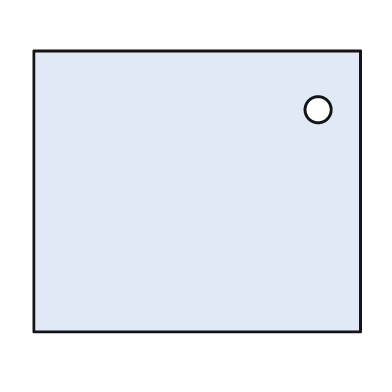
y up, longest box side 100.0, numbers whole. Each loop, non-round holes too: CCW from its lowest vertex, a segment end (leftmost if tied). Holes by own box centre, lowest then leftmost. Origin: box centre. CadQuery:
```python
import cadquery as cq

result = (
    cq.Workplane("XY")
    .moveTo(-50.0, -43.0)
    .lineTo(50.0, -43.0)
    .lineTo(50.0, 43.0)
    .lineTo(-50.0, 43.0)
    .close()
    .moveTo(37.0, 25.0)
    .circle(4.0)
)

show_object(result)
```